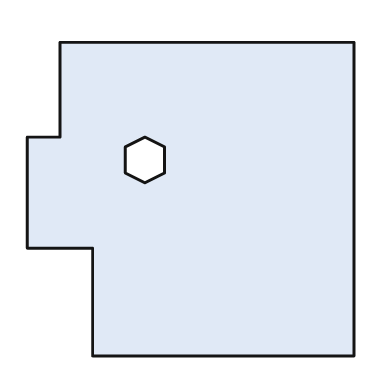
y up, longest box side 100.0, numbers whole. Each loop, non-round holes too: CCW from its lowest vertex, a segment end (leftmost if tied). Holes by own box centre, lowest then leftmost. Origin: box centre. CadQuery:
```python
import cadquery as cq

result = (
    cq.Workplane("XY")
    .moveTo(-30.0, -48.0)
    .lineTo(50.0, -48.0)
    .lineTo(50.0, 48.0)
    .lineTo(-40.0, 48.0)
    .lineTo(-40.0, 19.0)
    .lineTo(-50.0, 19.0)
    .lineTo(-50.0, -15.0)
    .lineTo(-30.0, -15.0)
    .close()
    .moveTo(-14.0, 5.0)
    .lineTo(-8.0, 8.0)
    .lineTo(-8.0, 16.0)
    .lineTo(-14.0, 19.0)
    .lineTo(-20.0, 16.0)
    .lineTo(-20.0, 8.0)
    .close()
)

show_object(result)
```